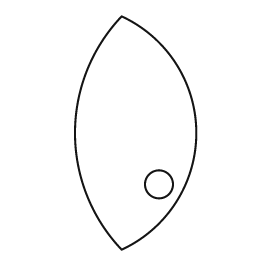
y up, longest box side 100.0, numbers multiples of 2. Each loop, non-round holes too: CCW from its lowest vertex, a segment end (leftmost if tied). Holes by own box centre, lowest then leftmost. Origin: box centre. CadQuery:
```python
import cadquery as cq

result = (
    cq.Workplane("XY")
    .moveTo(-6.0, -50.0)
    .threePointArc((26.0, 0.0), (-6.0, 50.0))
    .threePointArc((-26.0, 0.0), (-6.0, -50.0))
    .close()
    .moveTo(10.0, -22.0)
    .circle(6.0)
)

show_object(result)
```